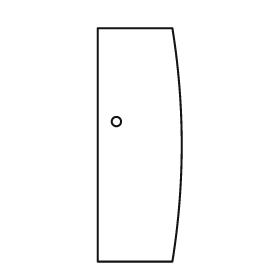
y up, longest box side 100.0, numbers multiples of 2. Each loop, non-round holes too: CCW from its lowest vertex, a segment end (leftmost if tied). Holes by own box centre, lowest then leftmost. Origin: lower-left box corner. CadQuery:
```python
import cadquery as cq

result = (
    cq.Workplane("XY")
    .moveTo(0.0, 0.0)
    .lineTo(32.0, 0.0)
    .threePointArc((36.0, 50.0), (32.0, 100.0))
    .lineTo(0.0, 100.0)
    .close()
    .moveTo(8.0, 60.0)
    .circle(2.0)
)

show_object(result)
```